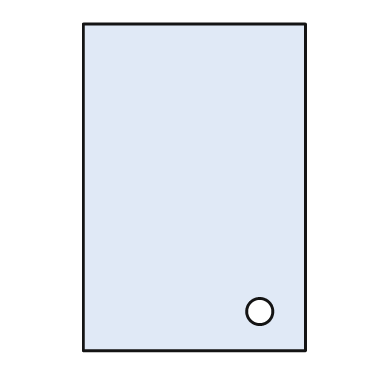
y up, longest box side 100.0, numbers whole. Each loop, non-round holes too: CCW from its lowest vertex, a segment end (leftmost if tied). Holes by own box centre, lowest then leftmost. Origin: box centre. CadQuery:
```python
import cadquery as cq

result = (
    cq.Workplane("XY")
    .moveTo(-34.0, -50.0)
    .lineTo(34.0, -50.0)
    .lineTo(34.0, 50.0)
    .lineTo(-34.0, 50.0)
    .close()
    .moveTo(20.0, -38.0)
    .circle(4.0)
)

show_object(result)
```